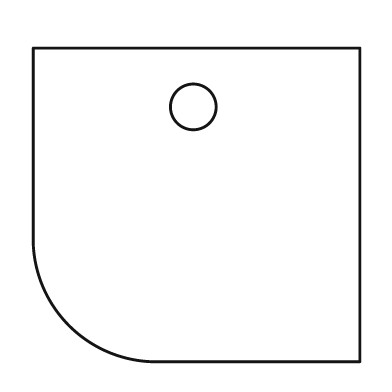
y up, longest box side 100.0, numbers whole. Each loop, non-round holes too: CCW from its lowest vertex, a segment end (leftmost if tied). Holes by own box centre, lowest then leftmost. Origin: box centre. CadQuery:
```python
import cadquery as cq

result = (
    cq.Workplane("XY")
    .moveTo(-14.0, -48.0)
    .lineTo(50.0, -48.0)
    .lineTo(50.0, 48.0)
    .lineTo(-50.0, 48.0)
    .lineTo(-50.0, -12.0)
    .threePointArc((-39.0, -37.0), (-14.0, -48.0))
    .close()
    .moveTo(-1.0, 30.0)
    .circle(7.0)
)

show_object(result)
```